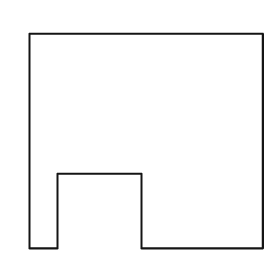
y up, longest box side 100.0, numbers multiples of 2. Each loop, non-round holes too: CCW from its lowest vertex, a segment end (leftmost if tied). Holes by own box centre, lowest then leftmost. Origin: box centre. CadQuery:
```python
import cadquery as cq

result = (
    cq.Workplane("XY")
    .moveTo(-50.0, -46.0)
    .lineTo(-38.0, -46.0)
    .lineTo(-38.0, -14.0)
    .lineTo(-2.0, -14.0)
    .lineTo(-2.0, -46.0)
    .lineTo(50.0, -46.0)
    .lineTo(50.0, 46.0)
    .lineTo(-50.0, 46.0)
    .close()
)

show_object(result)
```